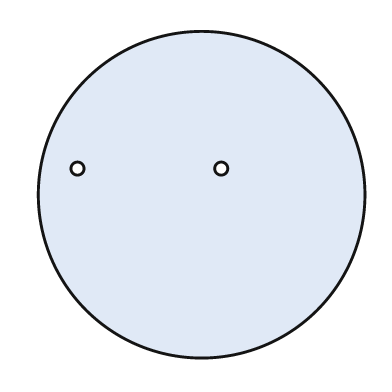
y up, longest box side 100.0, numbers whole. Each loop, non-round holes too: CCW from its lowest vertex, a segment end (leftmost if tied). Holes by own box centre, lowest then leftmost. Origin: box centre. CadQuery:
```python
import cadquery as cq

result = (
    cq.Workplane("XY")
    .moveTo(0.0, 0.0)
    .circle(50.0)
    .moveTo(-38.0, 8.0)
    .circle(2.0)
    .moveTo(6.0, 8.0)
    .circle(2.0)
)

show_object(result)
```